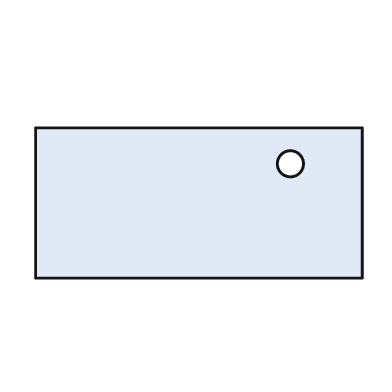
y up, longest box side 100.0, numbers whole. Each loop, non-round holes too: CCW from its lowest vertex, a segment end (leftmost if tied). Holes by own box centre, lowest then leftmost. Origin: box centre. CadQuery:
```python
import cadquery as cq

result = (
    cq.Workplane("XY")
    .moveTo(-50.0, -23.0)
    .lineTo(50.0, -23.0)
    .lineTo(50.0, 23.0)
    .lineTo(-50.0, 23.0)
    .close()
    .moveTo(28.0, 12.0)
    .circle(4.0)
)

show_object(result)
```